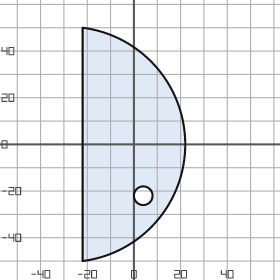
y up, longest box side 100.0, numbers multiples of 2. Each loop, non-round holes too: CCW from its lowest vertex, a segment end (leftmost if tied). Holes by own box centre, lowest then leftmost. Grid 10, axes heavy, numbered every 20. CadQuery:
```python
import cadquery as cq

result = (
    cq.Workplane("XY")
    .moveTo(-22.0, -50.0)
    .threePointArc((22.0, 0.0), (-22.0, 50.0))
    .close()
    .moveTo(4.0, -22.0)
    .circle(4.0)
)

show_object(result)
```